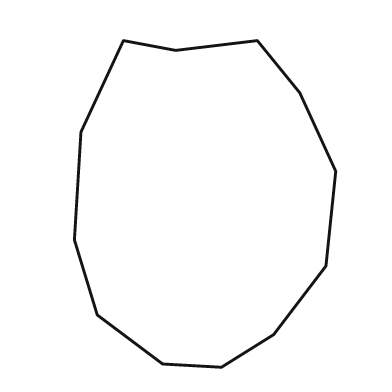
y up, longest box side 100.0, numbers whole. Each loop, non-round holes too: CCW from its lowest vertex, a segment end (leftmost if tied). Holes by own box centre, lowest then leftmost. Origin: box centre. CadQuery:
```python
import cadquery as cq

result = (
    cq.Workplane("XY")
    .moveTo(5.0, -50.0)
    .lineTo(21.0, -40.0)
    .lineTo(37.0, -19.0)
    .lineTo(40.0, 10.0)
    .lineTo(29.0, 34.0)
    .lineTo(16.0, 50.0)
    .lineTo(-9.0, 47.0)
    .lineTo(-25.0, 50.0)
    .lineTo(-38.0, 22.0)
    .lineTo(-40.0, -11.0)
    .lineTo(-33.0, -34.0)
    .lineTo(-13.0, -49.0)
    .close()
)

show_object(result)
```